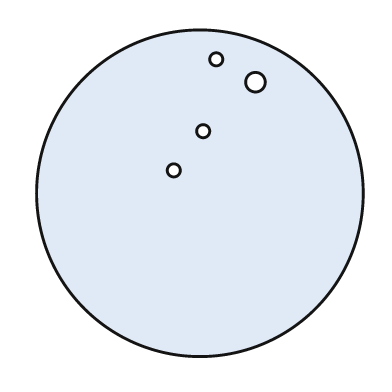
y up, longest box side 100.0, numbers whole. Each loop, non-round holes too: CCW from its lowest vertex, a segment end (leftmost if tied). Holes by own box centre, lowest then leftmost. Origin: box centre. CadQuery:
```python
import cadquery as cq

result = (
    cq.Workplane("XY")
    .moveTo(0.0, 0.0)
    .circle(50.0)
    .moveTo(-8.0, 7.0)
    .circle(2.0)
    .moveTo(1.0, 19.0)
    .circle(2.0)
    .moveTo(17.0, 34.0)
    .circle(3.0)
    .moveTo(5.0, 41.0)
    .circle(2.0)
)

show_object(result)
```